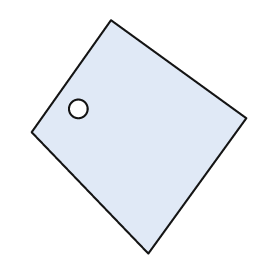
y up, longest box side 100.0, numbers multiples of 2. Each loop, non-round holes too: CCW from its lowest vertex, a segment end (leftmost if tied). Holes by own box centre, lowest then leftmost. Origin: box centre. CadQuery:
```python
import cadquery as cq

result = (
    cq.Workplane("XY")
    .moveTo(4.0, -50.0)
    .lineTo(46.0, 8.0)
    .lineTo(-12.0, 50.0)
    .lineTo(-46.0, 2.0)
    .close()
    .moveTo(-26.0, 12.0)
    .circle(4.0)
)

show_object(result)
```